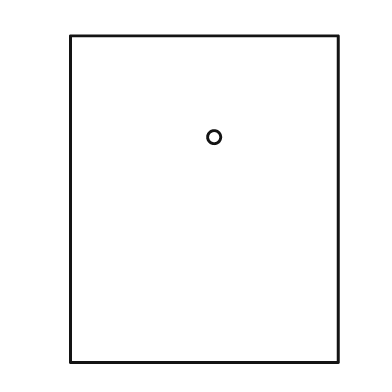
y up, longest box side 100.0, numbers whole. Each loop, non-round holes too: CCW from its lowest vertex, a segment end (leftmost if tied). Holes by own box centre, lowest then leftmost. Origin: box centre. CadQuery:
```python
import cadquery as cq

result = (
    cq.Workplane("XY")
    .moveTo(-41.0, -50.0)
    .lineTo(41.0, -50.0)
    .lineTo(41.0, 50.0)
    .lineTo(-41.0, 50.0)
    .close()
    .moveTo(3.0, 19.0)
    .circle(2.0)
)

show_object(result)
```